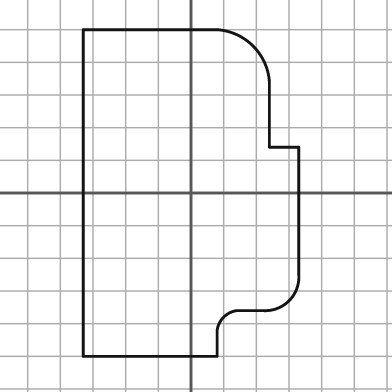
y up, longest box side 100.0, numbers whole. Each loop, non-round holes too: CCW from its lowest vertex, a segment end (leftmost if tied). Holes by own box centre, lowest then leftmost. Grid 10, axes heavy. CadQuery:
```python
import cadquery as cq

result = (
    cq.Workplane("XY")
    .moveTo(-33.0, -50.0)
    .lineTo(8.0, -50.0)
    .lineTo(8.0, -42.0)
    .threePointArc((10.0, -38.0), (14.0, -36.0))
    .lineTo(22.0, -36.0)
    .threePointArc((30.0, -33.0), (33.0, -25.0))
    .lineTo(33.0, 14.0)
    .lineTo(24.0, 14.0)
    .lineTo(24.0, 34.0)
    .threePointArc((19.0, 45.0), (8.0, 50.0))
    .lineTo(-33.0, 50.0)
    .close()
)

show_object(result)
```